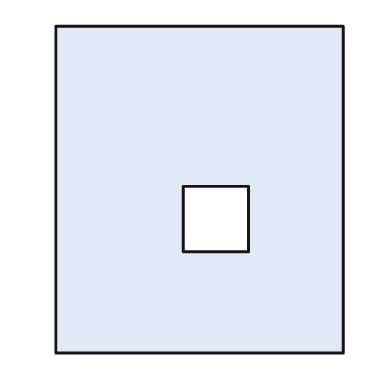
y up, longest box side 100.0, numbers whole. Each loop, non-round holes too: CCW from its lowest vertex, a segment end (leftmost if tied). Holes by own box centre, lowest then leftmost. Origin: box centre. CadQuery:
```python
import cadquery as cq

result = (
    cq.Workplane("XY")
    .moveTo(-44.0, -50.0)
    .lineTo(44.0, -50.0)
    .lineTo(44.0, 50.0)
    .lineTo(-44.0, 50.0)
    .close()
    .moveTo(-5.0, -19.0)
    .lineTo(15.0, -19.0)
    .lineTo(15.0, 1.0)
    .lineTo(-5.0, 1.0)
    .close()
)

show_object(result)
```